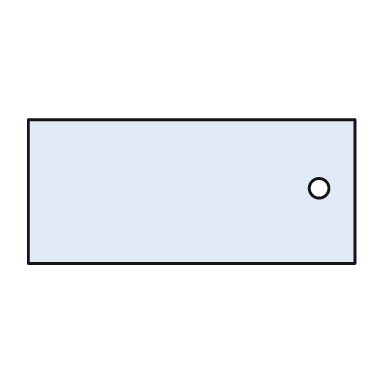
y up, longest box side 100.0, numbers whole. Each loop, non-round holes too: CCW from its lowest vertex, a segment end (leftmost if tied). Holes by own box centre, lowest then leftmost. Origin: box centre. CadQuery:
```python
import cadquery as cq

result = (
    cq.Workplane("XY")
    .moveTo(-50.0, -22.0)
    .lineTo(50.0, -22.0)
    .lineTo(50.0, 22.0)
    .lineTo(-50.0, 22.0)
    .close()
    .moveTo(39.0, 1.0)
    .circle(3.0)
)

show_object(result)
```